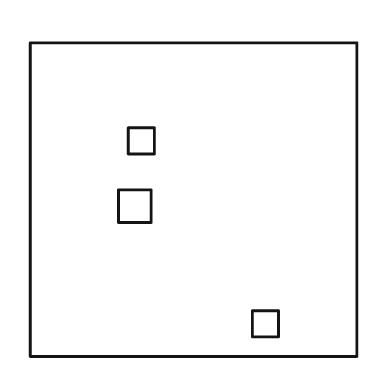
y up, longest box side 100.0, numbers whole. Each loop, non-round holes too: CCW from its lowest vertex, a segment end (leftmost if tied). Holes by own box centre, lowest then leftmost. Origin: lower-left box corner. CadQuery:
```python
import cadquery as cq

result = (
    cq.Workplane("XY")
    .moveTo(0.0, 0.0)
    .lineTo(100.0, 0.0)
    .lineTo(100.0, 96.0)
    .lineTo(0.0, 96.0)
    .close()
    .moveTo(68.0, 6.0)
    .lineTo(76.0, 6.0)
    .lineTo(76.0, 14.0)
    .lineTo(68.0, 14.0)
    .close()
    .moveTo(27.0, 41.0)
    .lineTo(37.0, 41.0)
    .lineTo(37.0, 51.0)
    .lineTo(27.0, 51.0)
    .close()
    .moveTo(30.0, 62.0)
    .lineTo(38.0, 62.0)
    .lineTo(38.0, 70.0)
    .lineTo(30.0, 70.0)
    .close()
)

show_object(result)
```